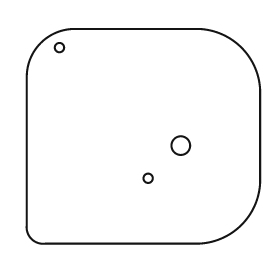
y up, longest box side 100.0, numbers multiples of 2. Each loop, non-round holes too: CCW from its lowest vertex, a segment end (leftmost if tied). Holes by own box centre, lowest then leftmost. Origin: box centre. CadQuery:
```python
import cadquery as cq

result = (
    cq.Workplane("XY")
    .moveTo(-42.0, -46.0)
    .lineTo(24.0, -46.0)
    .threePointArc((42.0, -38.0), (50.0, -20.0))
    .lineTo(50.0, 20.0)
    .threePointArc((42.0, 38.0), (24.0, 46.0))
    .lineTo(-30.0, 46.0)
    .threePointArc((-44.0, 40.0), (-50.0, 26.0))
    .lineTo(-50.0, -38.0)
    .threePointArc((-48.0, -44.0), (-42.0, -46.0))
    .close()
    .moveTo(2.0, -18.0)
    .circle(2.0)
    .moveTo(16.0, -4.0)
    .circle(4.0)
    .moveTo(-36.0, 38.0)
    .circle(2.0)
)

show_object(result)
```